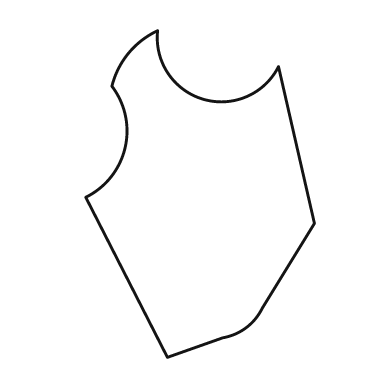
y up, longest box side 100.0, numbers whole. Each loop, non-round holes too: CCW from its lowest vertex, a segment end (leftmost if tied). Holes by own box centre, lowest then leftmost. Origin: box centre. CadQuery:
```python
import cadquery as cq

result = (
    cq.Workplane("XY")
    .moveTo(-10.0, -50.0)
    .lineTo(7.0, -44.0)
    .threePointArc((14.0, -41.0), (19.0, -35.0))
    .lineTo(35.0, -9.0)
    .lineTo(24.0, 39.0)
    .threePointArc((1.0, 29.0), (-13.0, 50.0))
    .threePointArc((-22.0, 43.0), (-27.0, 33.0))
    .threePointArc((-23.0, 14.0), (-35.0, -1.0))
    .close()
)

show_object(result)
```